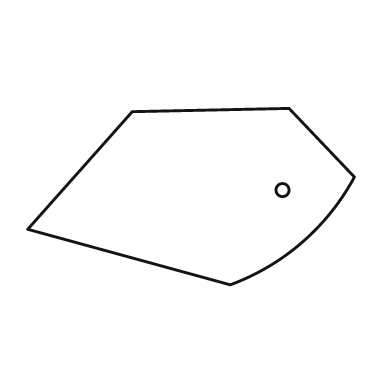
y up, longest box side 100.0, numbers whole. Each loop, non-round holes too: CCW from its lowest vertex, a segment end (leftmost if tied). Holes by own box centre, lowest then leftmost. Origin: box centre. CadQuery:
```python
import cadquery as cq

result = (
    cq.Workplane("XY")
    .moveTo(12.0, -27.0)
    .threePointArc((34.0, -14.0), (50.0, 6.0))
    .lineTo(30.0, 27.0)
    .lineTo(-18.0, 26.0)
    .lineTo(-50.0, -10.0)
    .close()
    .moveTo(28.0, 2.0)
    .circle(2.0)
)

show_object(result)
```